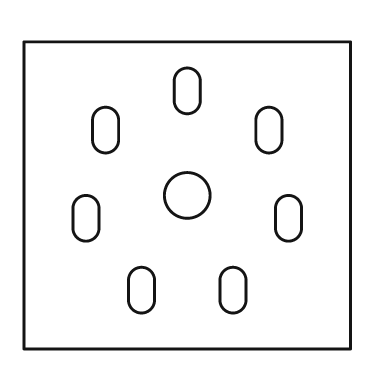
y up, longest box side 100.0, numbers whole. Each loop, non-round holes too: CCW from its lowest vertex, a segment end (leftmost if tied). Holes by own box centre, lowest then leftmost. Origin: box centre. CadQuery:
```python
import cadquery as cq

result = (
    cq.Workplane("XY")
    .moveTo(-50.0, -47.0)
    .lineTo(50.0, -47.0)
    .lineTo(50.0, 47.0)
    .lineTo(-50.0, 47.0)
    .close()
    .moveTo(-18.0, -32.0)
    .threePointArc((-14.0, -36.0), (-10.0, -32.0))
    .lineTo(-10.0, -26.0)
    .threePointArc((-14.0, -22.0), (-18.0, -26.0))
    .close()
    .moveTo(10.0, -32.0)
    .threePointArc((14.0, -36.0), (18.0, -32.0))
    .lineTo(18.0, -26.0)
    .threePointArc((14.0, -22.0), (10.0, -26.0))
    .close()
    .moveTo(-35.0, -10.0)
    .threePointArc((-31.0, -14.0), (-27.0, -10.0))
    .lineTo(-27.0, -4.0)
    .threePointArc((-31.0, 0.0), (-35.0, -4.0))
    .close()
    .moveTo(27.0, -10.0)
    .threePointArc((31.0, -14.0), (35.0, -10.0))
    .lineTo(35.0, -4.0)
    .threePointArc((31.0, 0.0), (27.0, -4.0))
    .close()
    .moveTo(0.0, 0.0)
    .circle(7.0)
    .moveTo(-29.0, 17.0)
    .threePointArc((-25.0, 13.0), (-21.0, 17.0))
    .lineTo(-21.0, 23.0)
    .threePointArc((-25.0, 27.0), (-29.0, 23.0))
    .close()
    .moveTo(21.0, 17.0)
    .threePointArc((25.0, 13.0), (29.0, 17.0))
    .lineTo(29.0, 23.0)
    .threePointArc((25.0, 27.0), (21.0, 23.0))
    .close()
    .moveTo(-4.0, 29.0)
    .threePointArc((0.0, 25.0), (4.0, 29.0))
    .lineTo(4.0, 35.0)
    .threePointArc((0.0, 39.0), (-4.0, 35.0))
    .close()
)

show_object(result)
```